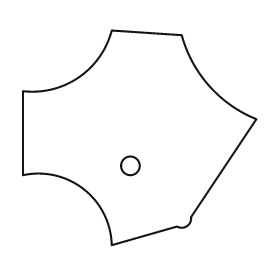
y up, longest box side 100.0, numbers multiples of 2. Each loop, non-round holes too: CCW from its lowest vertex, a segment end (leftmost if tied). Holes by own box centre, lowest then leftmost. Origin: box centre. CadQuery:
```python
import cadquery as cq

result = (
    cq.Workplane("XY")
    .moveTo(-12.0, -46.0)
    .lineTo(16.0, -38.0)
    .threePointArc((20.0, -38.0), (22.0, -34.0))
    .lineTo(50.0, 8.0)
    .threePointArc((30.0, 22.0), (18.0, 44.0))
    .lineTo(-12.0, 46.0)
    .threePointArc((-26.0, 26.0), (-50.0, 20.0))
    .lineTo(-50.0, -16.0)
    .threePointArc((-24.0, -22.0), (-12.0, -46.0))
    .close()
    .moveTo(-4.0, -12.0)
    .circle(4.0)
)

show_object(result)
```